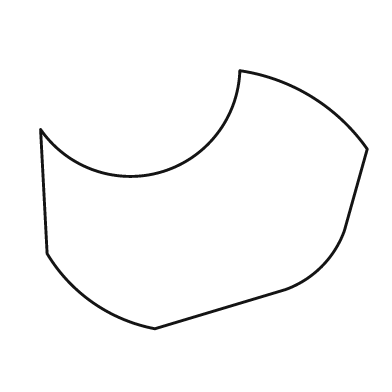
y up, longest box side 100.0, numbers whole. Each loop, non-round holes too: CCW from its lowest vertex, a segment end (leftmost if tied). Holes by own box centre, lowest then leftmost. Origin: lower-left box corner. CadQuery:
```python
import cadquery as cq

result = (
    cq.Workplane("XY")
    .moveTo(35.0, 0.0)
    .lineTo(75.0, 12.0)
    .threePointArc((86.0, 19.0), (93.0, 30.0))
    .lineTo(100.0, 55.0)
    .threePointArc((83.0, 71.0), (61.0, 79.0))
    .threePointArc((37.0, 48.0), (0.0, 61.0))
    .lineTo(2.0, 23.0)
    .threePointArc((16.0, 8.0), (35.0, 0.0))
    .close()
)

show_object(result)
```